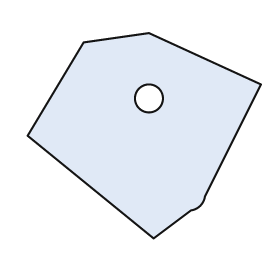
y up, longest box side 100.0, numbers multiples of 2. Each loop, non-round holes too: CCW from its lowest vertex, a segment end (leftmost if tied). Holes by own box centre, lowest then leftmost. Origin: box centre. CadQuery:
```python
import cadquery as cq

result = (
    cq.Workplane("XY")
    .moveTo(4.0, -44.0)
    .lineTo(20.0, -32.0)
    .threePointArc((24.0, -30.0), (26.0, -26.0))
    .lineTo(50.0, 22.0)
    .lineTo(2.0, 44.0)
    .lineTo(-26.0, 40.0)
    .lineTo(-50.0, 0.0)
    .close()
    .moveTo(2.0, 16.0)
    .circle(6.0)
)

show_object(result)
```